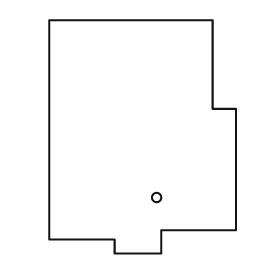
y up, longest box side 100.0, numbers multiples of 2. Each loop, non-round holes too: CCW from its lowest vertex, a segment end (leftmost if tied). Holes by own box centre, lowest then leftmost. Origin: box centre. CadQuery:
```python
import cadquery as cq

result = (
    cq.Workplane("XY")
    .moveTo(-12.0, -50.0)
    .lineTo(8.0, -50.0)
    .lineTo(8.0, -40.0)
    .lineTo(40.0, -40.0)
    .lineTo(40.0, 12.0)
    .lineTo(30.0, 12.0)
    .lineTo(30.0, 50.0)
    .lineTo(-40.0, 50.0)
    .lineTo(-40.0, -44.0)
    .lineTo(-12.0, -44.0)
    .close()
    .moveTo(6.0, -26.0)
    .circle(2.0)
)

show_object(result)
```